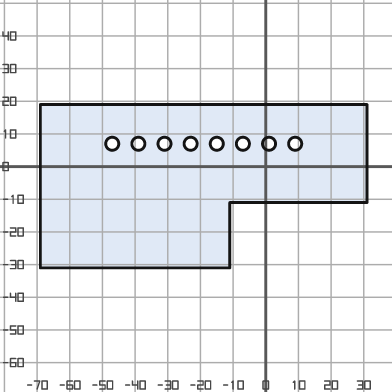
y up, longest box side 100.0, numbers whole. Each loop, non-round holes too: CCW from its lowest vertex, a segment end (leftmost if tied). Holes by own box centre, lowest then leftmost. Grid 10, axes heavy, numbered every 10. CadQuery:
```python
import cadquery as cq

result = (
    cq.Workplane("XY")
    .moveTo(-69.0, -31.0)
    .lineTo(-11.0, -31.0)
    .lineTo(-11.0, -11.0)
    .lineTo(31.0, -11.0)
    .lineTo(31.0, 19.0)
    .lineTo(-69.0, 19.0)
    .close()
    .moveTo(-47.0, 7.0)
    .circle(2.0)
    .moveTo(-39.0, 7.0)
    .circle(2.0)
    .moveTo(-31.0, 7.0)
    .circle(2.0)
    .moveTo(-23.0, 7.0)
    .circle(2.0)
    .moveTo(-15.0, 7.0)
    .circle(2.0)
    .moveTo(-7.0, 7.0)
    .circle(2.0)
    .moveTo(1.0, 7.0)
    .circle(2.0)
    .moveTo(9.0, 7.0)
    .circle(2.0)
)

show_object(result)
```